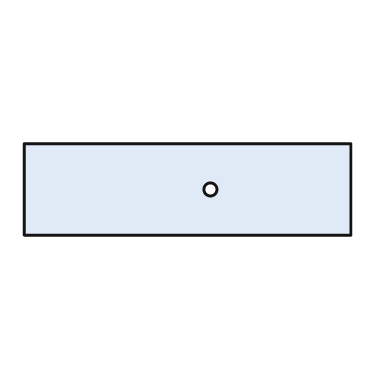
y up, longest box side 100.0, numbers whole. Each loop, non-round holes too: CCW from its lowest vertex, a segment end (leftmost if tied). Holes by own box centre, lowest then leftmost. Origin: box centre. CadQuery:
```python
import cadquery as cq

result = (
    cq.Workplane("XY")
    .moveTo(-50.0, -14.0)
    .lineTo(50.0, -14.0)
    .lineTo(50.0, 14.0)
    .lineTo(-50.0, 14.0)
    .close()
    .moveTo(7.0, 0.0)
    .circle(2.0)
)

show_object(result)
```